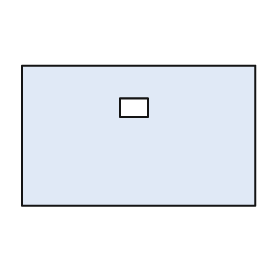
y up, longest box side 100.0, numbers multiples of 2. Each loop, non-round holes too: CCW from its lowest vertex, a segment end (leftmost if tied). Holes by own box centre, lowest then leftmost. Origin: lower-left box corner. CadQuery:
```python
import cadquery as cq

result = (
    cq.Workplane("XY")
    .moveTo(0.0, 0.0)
    .lineTo(100.0, 0.0)
    .lineTo(100.0, 60.0)
    .lineTo(0.0, 60.0)
    .close()
    .moveTo(42.0, 38.0)
    .lineTo(54.0, 38.0)
    .lineTo(54.0, 46.0)
    .lineTo(42.0, 46.0)
    .close()
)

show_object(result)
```